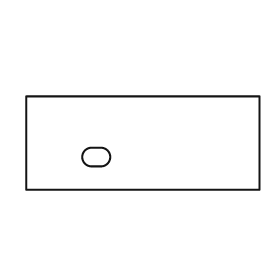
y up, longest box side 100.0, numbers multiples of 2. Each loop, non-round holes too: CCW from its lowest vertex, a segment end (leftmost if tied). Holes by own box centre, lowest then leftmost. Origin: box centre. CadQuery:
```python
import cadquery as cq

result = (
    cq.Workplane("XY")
    .moveTo(-50.0, -20.0)
    .lineTo(50.0, -20.0)
    .lineTo(50.0, 20.0)
    .lineTo(-50.0, 20.0)
    .close()
    .moveTo(-22.0, -10.0)
    .lineTo(-18.0, -10.0)
    .threePointArc((-14.0, -6.0), (-18.0, -2.0))
    .lineTo(-22.0, -2.0)
    .threePointArc((-26.0, -6.0), (-22.0, -10.0))
    .close()
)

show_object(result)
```